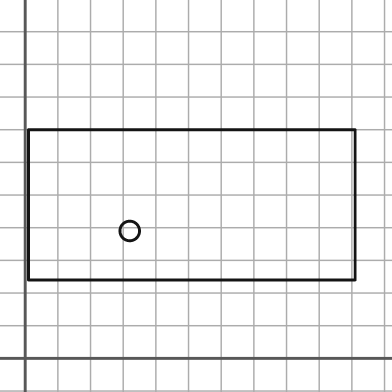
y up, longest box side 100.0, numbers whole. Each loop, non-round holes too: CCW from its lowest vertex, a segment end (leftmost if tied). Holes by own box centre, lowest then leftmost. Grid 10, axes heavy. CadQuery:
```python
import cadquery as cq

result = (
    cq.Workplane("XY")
    .moveTo(1.0, 24.0)
    .lineTo(101.0, 24.0)
    .lineTo(101.0, 70.0)
    .lineTo(1.0, 70.0)
    .close()
    .moveTo(32.0, 39.0)
    .circle(3.0)
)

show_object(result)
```